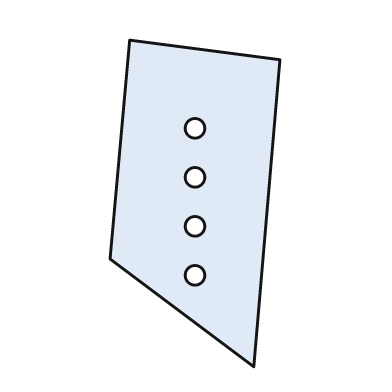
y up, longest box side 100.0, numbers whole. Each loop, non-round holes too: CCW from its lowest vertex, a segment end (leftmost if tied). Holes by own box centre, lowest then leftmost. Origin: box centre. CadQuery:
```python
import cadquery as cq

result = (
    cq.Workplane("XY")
    .moveTo(18.0, -50.0)
    .lineTo(26.0, 44.0)
    .lineTo(-20.0, 50.0)
    .lineTo(-26.0, -17.0)
    .close()
    .moveTo(0.0, -22.0)
    .circle(3.0)
    .moveTo(0.0, -7.0)
    .circle(3.0)
    .moveTo(0.0, 8.0)
    .circle(3.0)
    .moveTo(0.0, 23.0)
    .circle(3.0)
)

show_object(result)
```